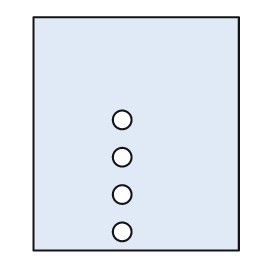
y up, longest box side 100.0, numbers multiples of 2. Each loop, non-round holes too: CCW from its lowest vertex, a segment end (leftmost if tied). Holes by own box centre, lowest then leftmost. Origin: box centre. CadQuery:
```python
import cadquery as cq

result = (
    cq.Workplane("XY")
    .moveTo(-44.0, -50.0)
    .lineTo(44.0, -50.0)
    .lineTo(44.0, 50.0)
    .lineTo(-44.0, 50.0)
    .close()
    .moveTo(-6.0, -42.0)
    .circle(4.0)
    .moveTo(-6.0, -26.0)
    .circle(4.0)
    .moveTo(-6.0, -10.0)
    .circle(4.0)
    .moveTo(-6.0, 6.0)
    .circle(4.0)
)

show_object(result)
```